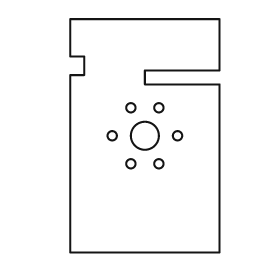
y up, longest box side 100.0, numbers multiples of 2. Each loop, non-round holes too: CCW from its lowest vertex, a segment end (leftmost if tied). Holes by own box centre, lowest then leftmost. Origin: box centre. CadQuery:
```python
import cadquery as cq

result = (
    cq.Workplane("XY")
    .moveTo(-32.0, -50.0)
    .lineTo(32.0, -50.0)
    .lineTo(32.0, 22.0)
    .lineTo(0.0, 22.0)
    .lineTo(0.0, 28.0)
    .lineTo(32.0, 28.0)
    .lineTo(32.0, 50.0)
    .lineTo(-32.0, 50.0)
    .lineTo(-32.0, 34.0)
    .lineTo(-26.0, 34.0)
    .lineTo(-26.0, 26.0)
    .lineTo(-32.0, 26.0)
    .close()
    .moveTo(-6.0, -12.0)
    .circle(2.0)
    .moveTo(6.0, -12.0)
    .circle(2.0)
    .moveTo(-14.0, 0.0)
    .circle(2.0)
    .moveTo(0.0, 0.0)
    .circle(6.0)
    .moveTo(14.0, 0.0)
    .circle(2.0)
    .moveTo(-6.0, 12.0)
    .circle(2.0)
    .moveTo(6.0, 12.0)
    .circle(2.0)
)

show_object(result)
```